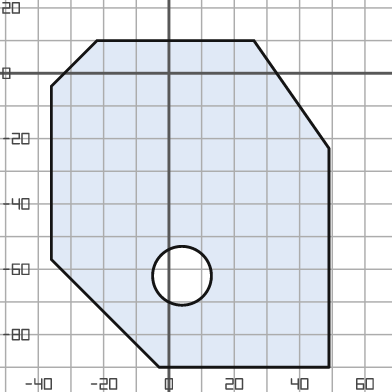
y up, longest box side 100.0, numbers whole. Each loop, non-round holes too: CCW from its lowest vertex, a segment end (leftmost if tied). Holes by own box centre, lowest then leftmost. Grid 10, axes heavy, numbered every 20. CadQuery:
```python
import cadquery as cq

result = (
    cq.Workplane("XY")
    .moveTo(-3.0, -90.0)
    .lineTo(49.0, -90.0)
    .lineTo(49.0, -23.0)
    .lineTo(26.0, 10.0)
    .lineTo(-22.0, 10.0)
    .lineTo(-36.0, -4.0)
    .lineTo(-36.0, -57.0)
    .close()
    .moveTo(4.0, -62.0)
    .circle(9.0)
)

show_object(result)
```